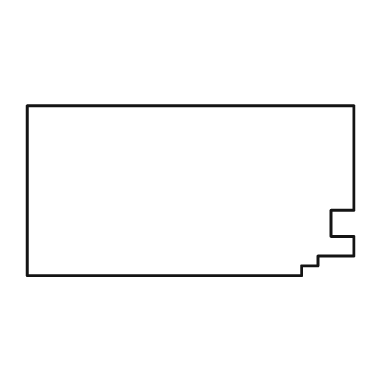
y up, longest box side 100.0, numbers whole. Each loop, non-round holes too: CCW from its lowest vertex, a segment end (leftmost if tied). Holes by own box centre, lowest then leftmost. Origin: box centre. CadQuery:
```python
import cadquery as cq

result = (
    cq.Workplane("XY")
    .moveTo(-50.0, -26.0)
    .lineTo(34.0, -26.0)
    .lineTo(34.0, -23.0)
    .lineTo(39.0, -23.0)
    .lineTo(39.0, -20.0)
    .lineTo(50.0, -20.0)
    .lineTo(50.0, -14.0)
    .lineTo(43.0, -14.0)
    .lineTo(43.0, -6.0)
    .lineTo(50.0, -6.0)
    .lineTo(50.0, 26.0)
    .lineTo(-50.0, 26.0)
    .close()
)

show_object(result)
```